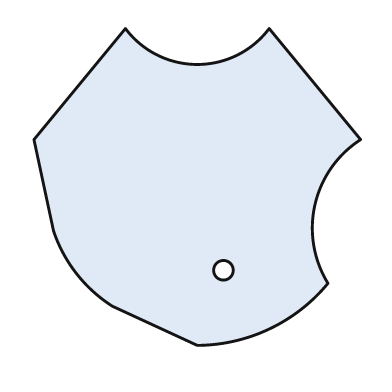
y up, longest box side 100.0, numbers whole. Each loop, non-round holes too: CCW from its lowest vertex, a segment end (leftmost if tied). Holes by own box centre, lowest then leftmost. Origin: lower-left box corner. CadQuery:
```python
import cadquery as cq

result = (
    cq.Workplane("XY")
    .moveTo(50.0, 0.0)
    .threePointArc((72.0, 5.0), (90.0, 19.0))
    .threePointArc((86.0, 43.0), (100.0, 63.0))
    .lineTo(72.0, 97.0)
    .threePointArc((50.0, 86.0), (28.0, 97.0))
    .lineTo(0.0, 63.0)
    .lineTo(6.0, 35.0)
    .threePointArc((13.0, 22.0), (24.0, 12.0))
    .close()
    .moveTo(58.0, 23.0)
    .circle(3.0)
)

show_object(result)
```